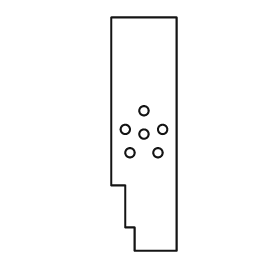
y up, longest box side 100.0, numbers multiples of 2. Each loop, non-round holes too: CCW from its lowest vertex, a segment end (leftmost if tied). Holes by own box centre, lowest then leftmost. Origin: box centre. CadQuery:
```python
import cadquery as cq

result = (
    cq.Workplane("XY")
    .moveTo(-4.0, -50.0)
    .lineTo(14.0, -50.0)
    .lineTo(14.0, 50.0)
    .lineTo(-14.0, 50.0)
    .lineTo(-14.0, -22.0)
    .lineTo(-8.0, -22.0)
    .lineTo(-8.0, -40.0)
    .lineTo(-4.0, -40.0)
    .close()
    .moveTo(-6.0, -8.0)
    .circle(2.0)
    .moveTo(6.0, -8.0)
    .circle(2.0)
    .moveTo(0.0, 0.0)
    .circle(2.0)
    .moveTo(-8.0, 2.0)
    .circle(2.0)
    .moveTo(8.0, 2.0)
    .circle(2.0)
    .moveTo(0.0, 10.0)
    .circle(2.0)
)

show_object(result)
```